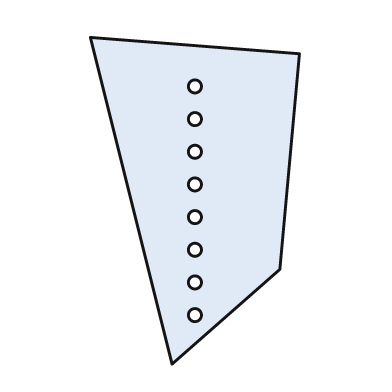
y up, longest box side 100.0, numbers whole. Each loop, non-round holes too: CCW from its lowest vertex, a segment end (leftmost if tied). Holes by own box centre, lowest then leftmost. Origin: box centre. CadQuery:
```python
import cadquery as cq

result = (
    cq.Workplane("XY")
    .moveTo(-7.0, -50.0)
    .lineTo(26.0, -21.0)
    .lineTo(32.0, 45.0)
    .lineTo(-32.0, 50.0)
    .close()
    .moveTo(0.0, -35.0)
    .circle(2.0)
    .moveTo(0.0, -25.0)
    .circle(2.0)
    .moveTo(0.0, -15.0)
    .circle(2.0)
    .moveTo(0.0, -5.0)
    .circle(2.0)
    .moveTo(0.0, 5.0)
    .circle(2.0)
    .moveTo(0.0, 15.0)
    .circle(2.0)
    .moveTo(0.0, 25.0)
    .circle(2.0)
    .moveTo(0.0, 35.0)
    .circle(2.0)
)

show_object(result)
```